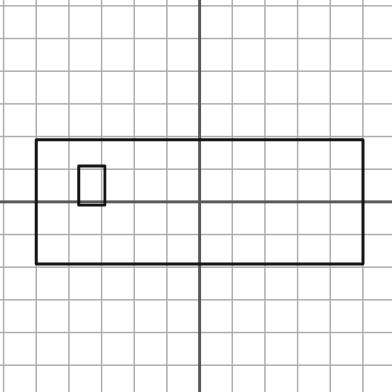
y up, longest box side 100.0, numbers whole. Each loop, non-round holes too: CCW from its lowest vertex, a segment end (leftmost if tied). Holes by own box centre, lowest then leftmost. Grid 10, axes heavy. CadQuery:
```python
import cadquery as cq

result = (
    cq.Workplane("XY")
    .moveTo(-50.0, -19.0)
    .lineTo(50.0, -19.0)
    .lineTo(50.0, 19.0)
    .lineTo(-50.0, 19.0)
    .close()
    .moveTo(-37.0, -1.0)
    .lineTo(-29.0, -1.0)
    .lineTo(-29.0, 11.0)
    .lineTo(-37.0, 11.0)
    .close()
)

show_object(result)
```